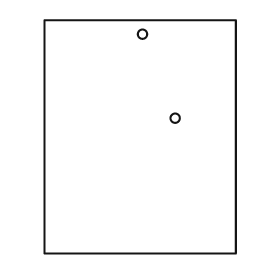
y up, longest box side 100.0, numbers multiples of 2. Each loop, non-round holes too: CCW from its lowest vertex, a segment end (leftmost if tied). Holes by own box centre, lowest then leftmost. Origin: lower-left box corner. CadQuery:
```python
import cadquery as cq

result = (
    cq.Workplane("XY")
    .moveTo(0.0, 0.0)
    .lineTo(82.0, 0.0)
    .lineTo(82.0, 100.0)
    .lineTo(0.0, 100.0)
    .close()
    .moveTo(56.0, 58.0)
    .circle(2.0)
    .moveTo(42.0, 94.0)
    .circle(2.0)
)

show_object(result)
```